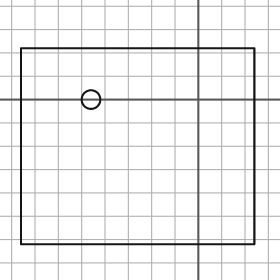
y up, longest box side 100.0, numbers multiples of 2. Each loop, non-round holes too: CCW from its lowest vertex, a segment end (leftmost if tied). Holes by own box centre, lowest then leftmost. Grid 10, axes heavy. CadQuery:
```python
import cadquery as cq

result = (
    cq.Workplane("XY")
    .moveTo(-76.0, -62.0)
    .lineTo(24.0, -62.0)
    .lineTo(24.0, 22.0)
    .lineTo(-76.0, 22.0)
    .close()
    .moveTo(-46.0, 0.0)
    .circle(4.0)
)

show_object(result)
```